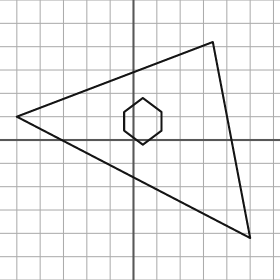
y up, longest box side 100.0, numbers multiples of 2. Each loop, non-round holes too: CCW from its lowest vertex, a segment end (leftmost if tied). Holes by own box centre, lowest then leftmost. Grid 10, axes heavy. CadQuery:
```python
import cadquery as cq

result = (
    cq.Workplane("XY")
    .moveTo(50.0, -42.0)
    .lineTo(34.0, 42.0)
    .lineTo(-50.0, 10.0)
    .close()
    .moveTo(4.0, -2.0)
    .lineTo(12.0, 4.0)
    .lineTo(12.0, 12.0)
    .lineTo(4.0, 18.0)
    .lineTo(-4.0, 12.0)
    .lineTo(-4.0, 4.0)
    .close()
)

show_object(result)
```